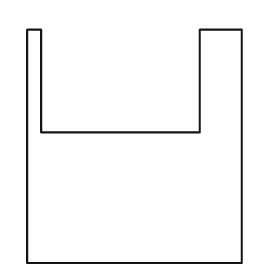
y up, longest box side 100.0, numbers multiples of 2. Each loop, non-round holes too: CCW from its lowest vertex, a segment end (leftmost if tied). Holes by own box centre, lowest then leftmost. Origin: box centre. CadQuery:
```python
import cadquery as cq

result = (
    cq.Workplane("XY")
    .moveTo(-46.0, -50.0)
    .lineTo(46.0, -50.0)
    .lineTo(46.0, 50.0)
    .lineTo(28.0, 50.0)
    .lineTo(28.0, 6.0)
    .lineTo(-40.0, 6.0)
    .lineTo(-40.0, 50.0)
    .lineTo(-46.0, 50.0)
    .close()
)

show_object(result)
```